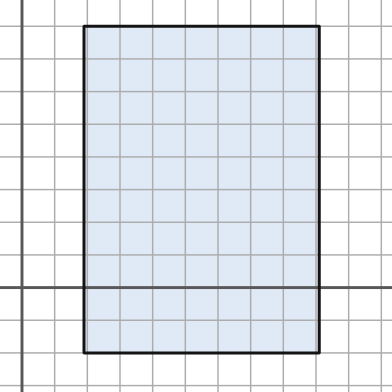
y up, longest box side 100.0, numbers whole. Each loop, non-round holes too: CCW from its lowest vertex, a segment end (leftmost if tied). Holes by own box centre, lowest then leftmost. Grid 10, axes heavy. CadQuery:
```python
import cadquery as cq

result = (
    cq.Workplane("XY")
    .moveTo(19.0, -20.0)
    .lineTo(91.0, -20.0)
    .lineTo(91.0, 80.0)
    .lineTo(19.0, 80.0)
    .close()
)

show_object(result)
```